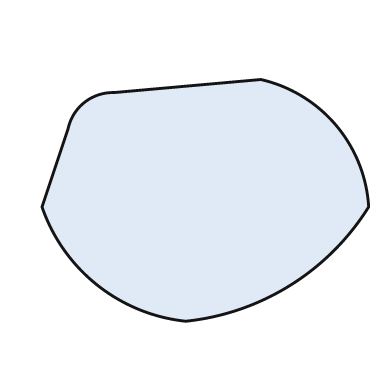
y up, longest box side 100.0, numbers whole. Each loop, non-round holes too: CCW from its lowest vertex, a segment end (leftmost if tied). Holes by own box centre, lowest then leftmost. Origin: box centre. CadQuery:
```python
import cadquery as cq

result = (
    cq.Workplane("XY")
    .moveTo(-6.0, -37.0)
    .threePointArc((26.0, -26.0), (50.0, -2.0))
    .threePointArc((40.0, 23.0), (17.0, 37.0))
    .lineTo(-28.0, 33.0)
    .threePointArc((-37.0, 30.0), (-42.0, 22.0))
    .lineTo(-50.0, -2.0)
    .threePointArc((-33.0, -26.0), (-6.0, -37.0))
    .close()
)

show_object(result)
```